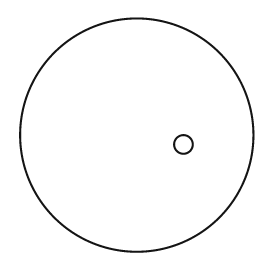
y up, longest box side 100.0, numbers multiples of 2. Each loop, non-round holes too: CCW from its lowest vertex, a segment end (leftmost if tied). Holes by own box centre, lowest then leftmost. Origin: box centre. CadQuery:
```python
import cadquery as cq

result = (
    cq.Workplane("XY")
    .moveTo(0.0, 0.0)
    .circle(50.0)
    .moveTo(20.0, -4.0)
    .circle(4.0)
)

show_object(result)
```